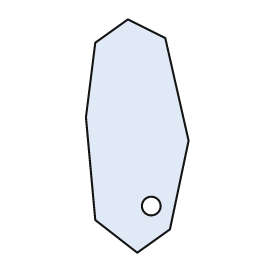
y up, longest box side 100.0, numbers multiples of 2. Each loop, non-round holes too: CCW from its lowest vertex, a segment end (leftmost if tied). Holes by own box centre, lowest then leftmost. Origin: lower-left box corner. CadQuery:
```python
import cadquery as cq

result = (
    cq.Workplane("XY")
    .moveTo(22.0, 0.0)
    .lineTo(36.0, 10.0)
    .lineTo(44.0, 48.0)
    .lineTo(34.0, 92.0)
    .lineTo(18.0, 100.0)
    .lineTo(4.0, 90.0)
    .lineTo(0.0, 58.0)
    .lineTo(4.0, 14.0)
    .close()
    .moveTo(28.0, 20.0)
    .circle(4.0)
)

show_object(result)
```